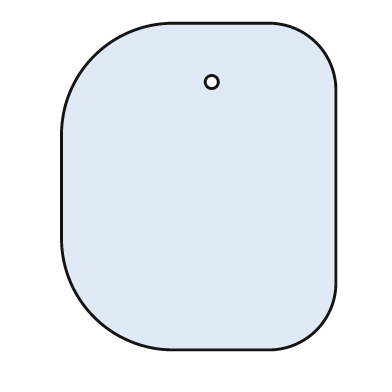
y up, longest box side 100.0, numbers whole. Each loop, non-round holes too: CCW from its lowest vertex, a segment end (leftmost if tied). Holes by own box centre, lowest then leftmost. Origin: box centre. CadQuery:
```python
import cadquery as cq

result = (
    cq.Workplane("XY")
    .moveTo(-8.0, -50.0)
    .lineTo(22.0, -50.0)
    .threePointArc((36.0, -44.0), (42.0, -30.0))
    .lineTo(42.0, 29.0)
    .threePointArc((36.0, 44.0), (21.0, 50.0))
    .lineTo(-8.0, 50.0)
    .threePointArc((-32.0, 40.0), (-42.0, 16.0))
    .lineTo(-42.0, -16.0)
    .threePointArc((-32.0, -40.0), (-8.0, -50.0))
    .close()
    .moveTo(4.0, 32.0)
    .circle(2.0)
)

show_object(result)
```